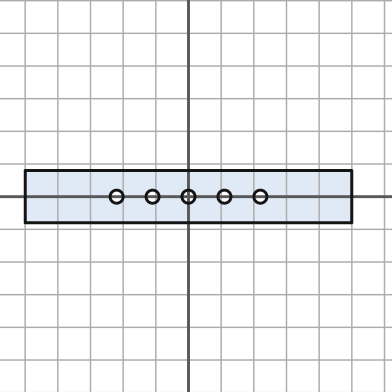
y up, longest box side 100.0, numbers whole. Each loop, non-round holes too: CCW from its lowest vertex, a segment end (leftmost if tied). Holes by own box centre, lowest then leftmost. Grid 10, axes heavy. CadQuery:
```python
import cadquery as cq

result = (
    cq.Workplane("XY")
    .moveTo(-50.0, -8.0)
    .lineTo(50.0, -8.0)
    .lineTo(50.0, 8.0)
    .lineTo(-50.0, 8.0)
    .close()
    .moveTo(-22.0, 0.0)
    .circle(2.0)
    .moveTo(-11.0, 0.0)
    .circle(2.0)
    .moveTo(0.0, 0.0)
    .circle(2.0)
    .moveTo(11.0, 0.0)
    .circle(2.0)
    .moveTo(22.0, 0.0)
    .circle(2.0)
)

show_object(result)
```